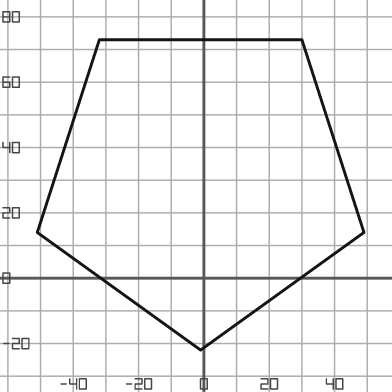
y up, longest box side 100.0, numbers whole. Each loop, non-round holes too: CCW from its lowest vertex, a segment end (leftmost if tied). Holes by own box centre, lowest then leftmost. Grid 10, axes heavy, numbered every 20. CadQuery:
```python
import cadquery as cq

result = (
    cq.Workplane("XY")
    .moveTo(-1.0, -22.0)
    .lineTo(49.0, 14.0)
    .lineTo(30.0, 73.0)
    .lineTo(-32.0, 73.0)
    .lineTo(-51.0, 14.0)
    .close()
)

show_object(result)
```